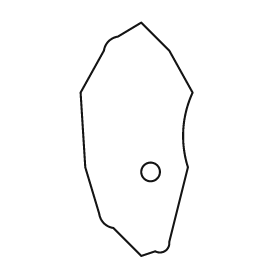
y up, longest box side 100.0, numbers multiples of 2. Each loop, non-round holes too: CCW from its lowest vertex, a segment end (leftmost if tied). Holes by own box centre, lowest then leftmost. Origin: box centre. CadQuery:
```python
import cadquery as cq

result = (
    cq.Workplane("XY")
    .moveTo(2.0, -50.0)
    .lineTo(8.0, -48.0)
    .threePointArc((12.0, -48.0), (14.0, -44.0))
    .lineTo(22.0, -12.0)
    .threePointArc((20.0, 4.0), (24.0, 20.0))
    .lineTo(14.0, 38.0)
    .lineTo(2.0, 50.0)
    .lineTo(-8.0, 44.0)
    .threePointArc((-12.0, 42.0), (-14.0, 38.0))
    .lineTo(-24.0, 20.0)
    .lineTo(-22.0, -12.0)
    .lineTo(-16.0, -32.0)
    .threePointArc((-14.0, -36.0), (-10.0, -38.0))
    .close()
    .moveTo(6.0, -14.0)
    .circle(4.0)
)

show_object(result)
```